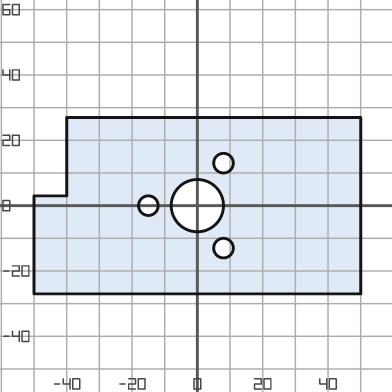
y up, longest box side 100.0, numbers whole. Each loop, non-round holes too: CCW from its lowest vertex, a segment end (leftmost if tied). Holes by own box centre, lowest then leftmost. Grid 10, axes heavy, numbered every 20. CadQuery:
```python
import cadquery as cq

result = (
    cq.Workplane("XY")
    .moveTo(-50.0, -27.0)
    .lineTo(50.0, -27.0)
    .lineTo(50.0, 27.0)
    .lineTo(-40.0, 27.0)
    .lineTo(-40.0, 3.0)
    .lineTo(-50.0, 3.0)
    .close()
    .moveTo(8.0, -13.0)
    .circle(3.0)
    .moveTo(-15.0, 0.0)
    .circle(3.0)
    .moveTo(0.0, 0.0)
    .circle(8.0)
    .moveTo(8.0, 13.0)
    .circle(3.0)
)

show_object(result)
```